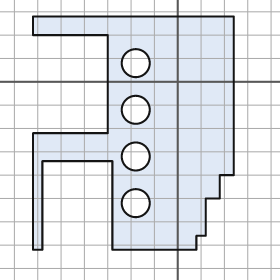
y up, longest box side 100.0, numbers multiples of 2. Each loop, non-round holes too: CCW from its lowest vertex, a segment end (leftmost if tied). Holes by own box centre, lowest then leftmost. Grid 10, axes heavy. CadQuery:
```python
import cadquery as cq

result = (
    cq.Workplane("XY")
    .moveTo(-62.0, -72.0)
    .lineTo(-58.0, -72.0)
    .lineTo(-58.0, -34.0)
    .lineTo(-28.0, -34.0)
    .lineTo(-28.0, -72.0)
    .lineTo(8.0, -72.0)
    .lineTo(8.0, -66.0)
    .lineTo(12.0, -66.0)
    .lineTo(12.0, -50.0)
    .lineTo(18.0, -50.0)
    .lineTo(18.0, -40.0)
    .lineTo(24.0, -40.0)
    .lineTo(24.0, 28.0)
    .lineTo(-62.0, 28.0)
    .lineTo(-62.0, 20.0)
    .lineTo(-30.0, 20.0)
    .lineTo(-30.0, -22.0)
    .lineTo(-62.0, -22.0)
    .close()
    .moveTo(-18.0, -52.0)
    .circle(6.0)
    .moveTo(-18.0, -32.0)
    .circle(6.0)
    .moveTo(-18.0, -12.0)
    .circle(6.0)
    .moveTo(-18.0, 8.0)
    .circle(6.0)
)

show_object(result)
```